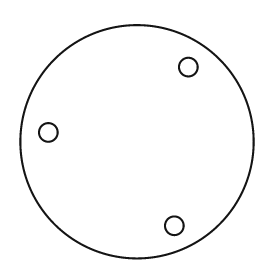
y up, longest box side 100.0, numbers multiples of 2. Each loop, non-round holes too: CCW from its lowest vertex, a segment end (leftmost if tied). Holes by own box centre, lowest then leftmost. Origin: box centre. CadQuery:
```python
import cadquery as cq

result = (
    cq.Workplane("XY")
    .moveTo(0.0, 0.0)
    .circle(50.0)
    .moveTo(16.0, -36.0)
    .circle(4.0)
    .moveTo(-38.0, 4.0)
    .circle(4.0)
    .moveTo(22.0, 32.0)
    .circle(4.0)
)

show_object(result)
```